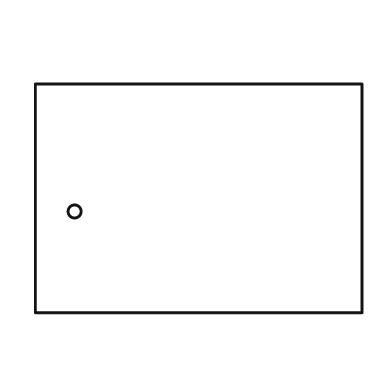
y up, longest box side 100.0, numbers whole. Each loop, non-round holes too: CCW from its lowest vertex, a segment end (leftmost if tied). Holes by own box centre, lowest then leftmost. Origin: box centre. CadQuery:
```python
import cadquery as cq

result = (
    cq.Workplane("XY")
    .moveTo(-50.0, -35.0)
    .lineTo(50.0, -35.0)
    .lineTo(50.0, 35.0)
    .lineTo(-50.0, 35.0)
    .close()
    .moveTo(-38.0, -4.0)
    .circle(2.0)
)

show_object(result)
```